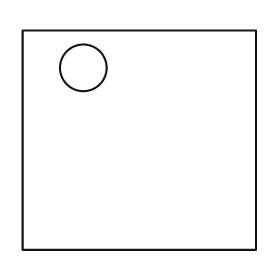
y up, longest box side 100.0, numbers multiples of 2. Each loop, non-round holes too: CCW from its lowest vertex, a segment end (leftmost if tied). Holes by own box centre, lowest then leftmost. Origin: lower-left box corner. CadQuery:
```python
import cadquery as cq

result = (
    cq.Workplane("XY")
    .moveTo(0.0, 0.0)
    .lineTo(100.0, 0.0)
    .lineTo(100.0, 94.0)
    .lineTo(0.0, 94.0)
    .close()
    .moveTo(26.0, 78.0)
    .circle(10.0)
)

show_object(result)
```